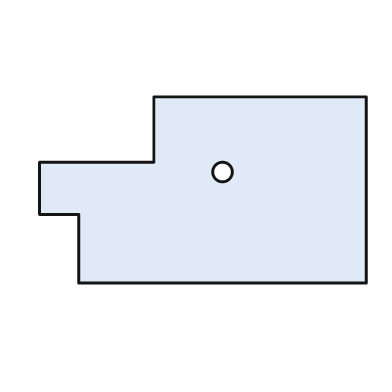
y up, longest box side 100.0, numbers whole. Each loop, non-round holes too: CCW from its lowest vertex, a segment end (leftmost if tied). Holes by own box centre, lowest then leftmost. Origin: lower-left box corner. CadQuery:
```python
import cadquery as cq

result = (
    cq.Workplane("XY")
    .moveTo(12.0, 0.0)
    .lineTo(100.0, 0.0)
    .lineTo(100.0, 57.0)
    .lineTo(35.0, 57.0)
    .lineTo(35.0, 37.0)
    .lineTo(0.0, 37.0)
    .lineTo(0.0, 21.0)
    .lineTo(12.0, 21.0)
    .close()
    .moveTo(56.0, 34.0)
    .circle(3.0)
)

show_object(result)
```